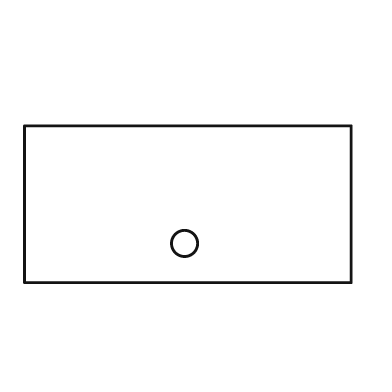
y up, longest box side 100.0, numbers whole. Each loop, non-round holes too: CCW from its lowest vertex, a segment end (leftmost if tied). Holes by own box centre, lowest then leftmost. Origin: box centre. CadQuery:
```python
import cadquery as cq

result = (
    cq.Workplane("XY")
    .moveTo(-50.0, -24.0)
    .lineTo(50.0, -24.0)
    .lineTo(50.0, 24.0)
    .lineTo(-50.0, 24.0)
    .close()
    .moveTo(-1.0, -12.0)
    .circle(4.0)
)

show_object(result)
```